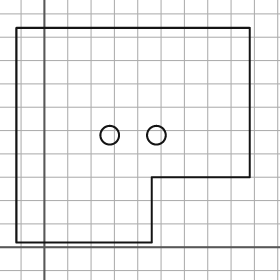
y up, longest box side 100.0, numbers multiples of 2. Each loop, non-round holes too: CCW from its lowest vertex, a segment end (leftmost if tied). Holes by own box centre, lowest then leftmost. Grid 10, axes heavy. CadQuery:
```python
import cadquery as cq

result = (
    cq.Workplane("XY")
    .moveTo(-12.0, 2.0)
    .lineTo(46.0, 2.0)
    .lineTo(46.0, 30.0)
    .lineTo(88.0, 30.0)
    .lineTo(88.0, 94.0)
    .lineTo(-12.0, 94.0)
    .close()
    .moveTo(28.0, 48.0)
    .circle(4.0)
    .moveTo(48.0, 48.0)
    .circle(4.0)
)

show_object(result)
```